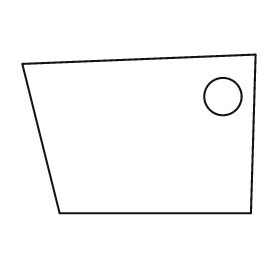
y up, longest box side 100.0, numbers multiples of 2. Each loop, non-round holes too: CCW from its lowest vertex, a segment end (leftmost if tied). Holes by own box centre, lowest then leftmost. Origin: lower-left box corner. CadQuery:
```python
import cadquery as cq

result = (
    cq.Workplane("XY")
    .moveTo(16.0, 0.0)
    .lineTo(98.0, 0.0)
    .lineTo(100.0, 68.0)
    .lineTo(0.0, 64.0)
    .close()
    .moveTo(86.0, 50.0)
    .circle(8.0)
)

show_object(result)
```